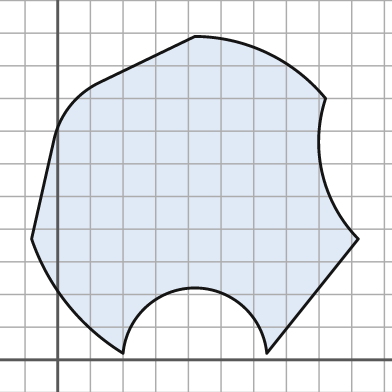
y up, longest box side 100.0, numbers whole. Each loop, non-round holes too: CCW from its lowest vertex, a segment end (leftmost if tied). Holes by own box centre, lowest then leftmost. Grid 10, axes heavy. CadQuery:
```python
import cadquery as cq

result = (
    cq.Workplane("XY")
    .moveTo(20.0, 2.0)
    .threePointArc((42.0, 22.0), (64.0, 2.0))
    .lineTo(92.0, 37.0)
    .threePointArc((81.0, 57.0), (82.0, 80.0))
    .threePointArc((64.0, 94.0), (42.0, 99.0))
    .lineTo(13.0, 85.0)
    .threePointArc((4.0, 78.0), (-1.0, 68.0))
    .lineTo(-8.0, 37.0)
    .threePointArc((3.0, 17.0), (20.0, 2.0))
    .close()
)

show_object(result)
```